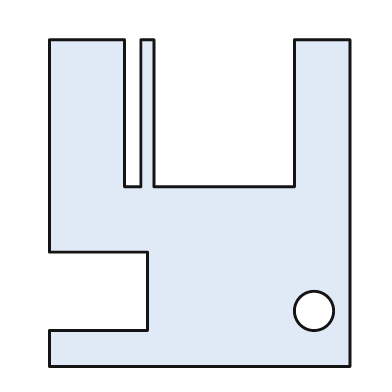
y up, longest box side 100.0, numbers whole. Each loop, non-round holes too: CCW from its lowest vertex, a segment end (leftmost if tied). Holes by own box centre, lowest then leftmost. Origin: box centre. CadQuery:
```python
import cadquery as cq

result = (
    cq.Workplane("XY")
    .moveTo(-46.0, -50.0)
    .lineTo(46.0, -50.0)
    .lineTo(46.0, 50.0)
    .lineTo(29.0, 50.0)
    .lineTo(29.0, 5.0)
    .lineTo(-14.0, 5.0)
    .lineTo(-14.0, 50.0)
    .lineTo(-18.0, 50.0)
    .lineTo(-18.0, 5.0)
    .lineTo(-23.0, 5.0)
    .lineTo(-23.0, 50.0)
    .lineTo(-46.0, 50.0)
    .lineTo(-46.0, -15.0)
    .lineTo(-16.0, -15.0)
    .lineTo(-16.0, -39.0)
    .lineTo(-46.0, -39.0)
    .close()
    .moveTo(35.0, -33.0)
    .circle(6.0)
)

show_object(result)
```